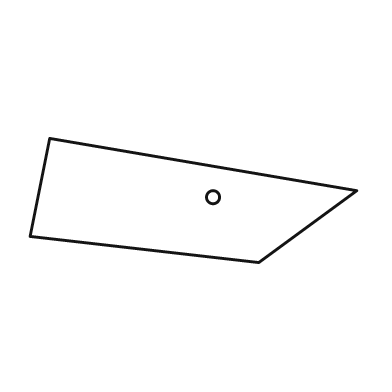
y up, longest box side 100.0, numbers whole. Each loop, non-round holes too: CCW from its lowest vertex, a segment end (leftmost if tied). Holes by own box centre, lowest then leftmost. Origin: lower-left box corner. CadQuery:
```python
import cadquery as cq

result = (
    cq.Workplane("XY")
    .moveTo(70.0, 0.0)
    .lineTo(100.0, 22.0)
    .lineTo(6.0, 38.0)
    .lineTo(0.0, 8.0)
    .close()
    .moveTo(56.0, 20.0)
    .circle(2.0)
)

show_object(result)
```